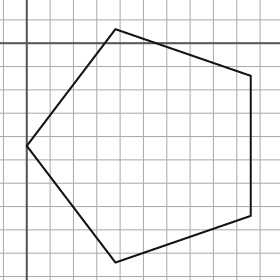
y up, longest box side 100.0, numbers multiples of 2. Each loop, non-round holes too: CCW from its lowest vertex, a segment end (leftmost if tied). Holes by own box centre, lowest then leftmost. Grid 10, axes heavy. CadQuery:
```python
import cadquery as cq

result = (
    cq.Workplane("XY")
    .moveTo(38.0, -94.0)
    .lineTo(96.0, -74.0)
    .lineTo(96.0, -14.0)
    .lineTo(38.0, 6.0)
    .lineTo(0.0, -44.0)
    .close()
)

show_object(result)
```